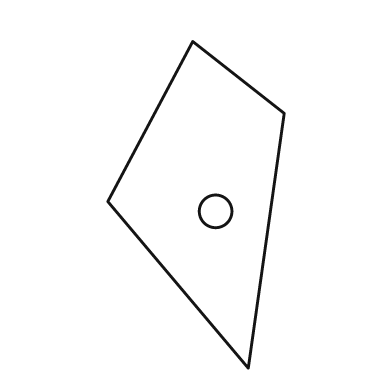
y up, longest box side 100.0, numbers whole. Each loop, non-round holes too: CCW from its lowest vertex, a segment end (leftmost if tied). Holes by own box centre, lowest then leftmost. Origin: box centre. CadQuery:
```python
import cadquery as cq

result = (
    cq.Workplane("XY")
    .moveTo(16.0, -50.0)
    .lineTo(27.0, 28.0)
    .lineTo(-1.0, 50.0)
    .lineTo(-27.0, 1.0)
    .close()
    .moveTo(6.0, -2.0)
    .circle(5.0)
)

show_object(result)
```